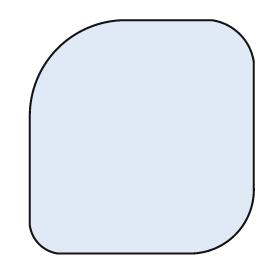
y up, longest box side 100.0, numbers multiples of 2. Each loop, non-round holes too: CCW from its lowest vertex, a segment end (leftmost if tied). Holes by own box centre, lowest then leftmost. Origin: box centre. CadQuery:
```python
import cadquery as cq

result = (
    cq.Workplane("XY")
    .moveTo(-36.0, -50.0)
    .lineTo(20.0, -50.0)
    .threePointArc((40.0, -42.0), (48.0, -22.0))
    .lineTo(48.0, 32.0)
    .threePointArc((42.0, 44.0), (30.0, 50.0))
    .lineTo(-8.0, 50.0)
    .threePointArc((-36.0, 38.0), (-48.0, 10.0))
    .lineTo(-48.0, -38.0)
    .threePointArc((-44.0, -46.0), (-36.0, -50.0))
    .close()
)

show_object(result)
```